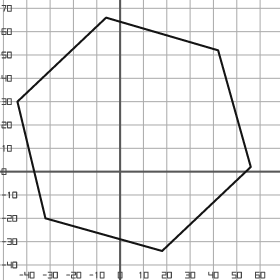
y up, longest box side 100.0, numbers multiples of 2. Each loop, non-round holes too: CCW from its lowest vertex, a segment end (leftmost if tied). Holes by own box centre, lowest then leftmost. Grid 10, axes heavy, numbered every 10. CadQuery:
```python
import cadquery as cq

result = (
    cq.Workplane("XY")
    .moveTo(18.0, -34.0)
    .lineTo(56.0, 2.0)
    .lineTo(42.0, 52.0)
    .lineTo(-6.0, 66.0)
    .lineTo(-44.0, 30.0)
    .lineTo(-32.0, -20.0)
    .close()
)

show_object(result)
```